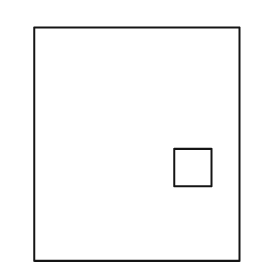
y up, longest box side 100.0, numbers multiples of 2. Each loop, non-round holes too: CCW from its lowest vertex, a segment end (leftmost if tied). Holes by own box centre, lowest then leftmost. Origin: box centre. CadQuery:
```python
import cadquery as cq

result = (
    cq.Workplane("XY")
    .moveTo(-44.0, -50.0)
    .lineTo(44.0, -50.0)
    .lineTo(44.0, 50.0)
    .lineTo(-44.0, 50.0)
    .close()
    .moveTo(16.0, -18.0)
    .lineTo(32.0, -18.0)
    .lineTo(32.0, -2.0)
    .lineTo(16.0, -2.0)
    .close()
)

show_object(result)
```